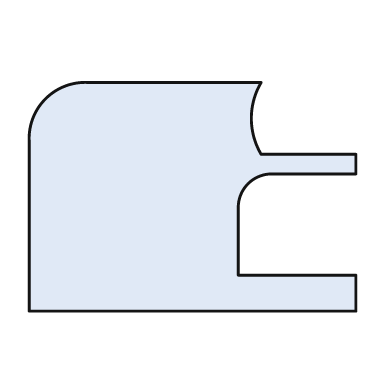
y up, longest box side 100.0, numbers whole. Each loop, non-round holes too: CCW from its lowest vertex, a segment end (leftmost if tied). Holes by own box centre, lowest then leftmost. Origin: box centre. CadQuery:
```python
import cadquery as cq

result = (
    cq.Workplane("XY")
    .moveTo(-50.0, -35.0)
    .lineTo(50.0, -35.0)
    .lineTo(50.0, -24.0)
    .lineTo(14.0, -24.0)
    .lineTo(14.0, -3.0)
    .threePointArc((17.0, 4.0), (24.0, 7.0))
    .lineTo(50.0, 7.0)
    .lineTo(50.0, 13.0)
    .lineTo(21.0, 13.0)
    .threePointArc((18.0, 24.0), (21.0, 35.0))
    .lineTo(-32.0, 35.0)
    .threePointArc((-45.0, 30.0), (-50.0, 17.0))
    .close()
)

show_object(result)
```